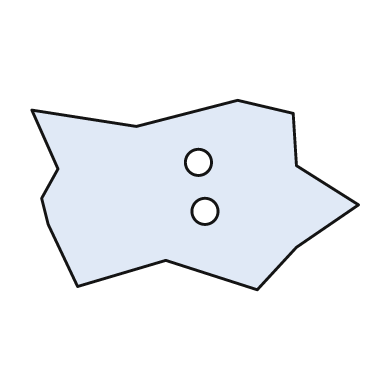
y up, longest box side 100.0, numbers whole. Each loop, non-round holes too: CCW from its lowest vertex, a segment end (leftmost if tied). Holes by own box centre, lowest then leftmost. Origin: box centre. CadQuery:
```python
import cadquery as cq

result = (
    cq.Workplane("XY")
    .moveTo(19.0, -29.0)
    .lineTo(31.0, -16.0)
    .lineTo(50.0, -3.0)
    .lineTo(31.0, 9.0)
    .lineTo(30.0, 25.0)
    .lineTo(13.0, 29.0)
    .lineTo(-18.0, 21.0)
    .lineTo(-50.0, 26.0)
    .lineTo(-42.0, 8.0)
    .lineTo(-47.0, -1.0)
    .lineTo(-45.0, -9.0)
    .lineTo(-36.0, -28.0)
    .lineTo(-9.0, -20.0)
    .close()
    .moveTo(3.0, -5.0)
    .circle(4.0)
    .moveTo(1.0, 10.0)
    .circle(4.0)
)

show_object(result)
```